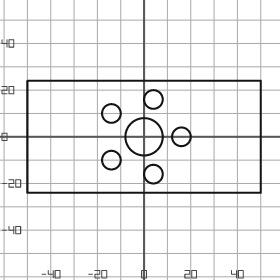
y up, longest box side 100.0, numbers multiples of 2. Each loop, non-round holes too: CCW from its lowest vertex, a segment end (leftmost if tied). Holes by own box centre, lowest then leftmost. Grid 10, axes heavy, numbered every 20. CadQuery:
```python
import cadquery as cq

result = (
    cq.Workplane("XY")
    .moveTo(-50.0, -24.0)
    .lineTo(50.0, -24.0)
    .lineTo(50.0, 24.0)
    .lineTo(-50.0, 24.0)
    .close()
    .moveTo(4.0, -16.0)
    .circle(4.0)
    .moveTo(-14.0, -10.0)
    .circle(4.0)
    .moveTo(0.0, 0.0)
    .circle(8.0)
    .moveTo(16.0, 0.0)
    .circle(4.0)
    .moveTo(-14.0, 10.0)
    .circle(4.0)
    .moveTo(4.0, 16.0)
    .circle(4.0)
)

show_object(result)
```